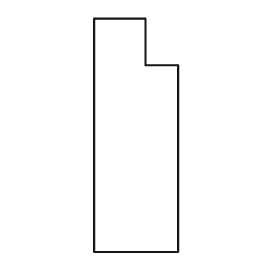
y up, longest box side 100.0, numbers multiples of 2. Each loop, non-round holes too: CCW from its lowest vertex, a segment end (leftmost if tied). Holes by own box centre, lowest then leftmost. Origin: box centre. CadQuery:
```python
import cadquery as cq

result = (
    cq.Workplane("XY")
    .moveTo(-18.0, -50.0)
    .lineTo(18.0, -50.0)
    .lineTo(18.0, 30.0)
    .lineTo(4.0, 30.0)
    .lineTo(4.0, 50.0)
    .lineTo(-18.0, 50.0)
    .close()
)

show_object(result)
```